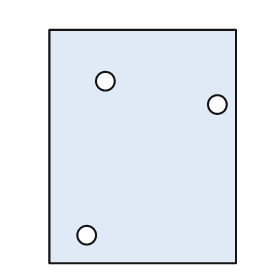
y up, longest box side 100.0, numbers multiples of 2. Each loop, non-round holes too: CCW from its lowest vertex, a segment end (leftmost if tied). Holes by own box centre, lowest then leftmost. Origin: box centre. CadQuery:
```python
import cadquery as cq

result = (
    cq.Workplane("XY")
    .moveTo(-40.0, -50.0)
    .lineTo(40.0, -50.0)
    .lineTo(40.0, 50.0)
    .lineTo(-40.0, 50.0)
    .close()
    .moveTo(-24.0, -38.0)
    .circle(4.0)
    .moveTo(32.0, 18.0)
    .circle(4.0)
    .moveTo(-16.0, 28.0)
    .circle(4.0)
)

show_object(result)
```